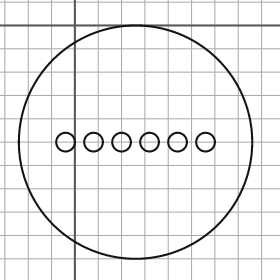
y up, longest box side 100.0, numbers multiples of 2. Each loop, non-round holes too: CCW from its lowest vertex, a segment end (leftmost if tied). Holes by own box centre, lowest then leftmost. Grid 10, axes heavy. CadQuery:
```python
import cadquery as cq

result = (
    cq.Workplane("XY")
    .moveTo(26.0, -50.0)
    .circle(50.0)
    .moveTo(-4.0, -50.0)
    .circle(4.0)
    .moveTo(8.0, -50.0)
    .circle(4.0)
    .moveTo(20.0, -50.0)
    .circle(4.0)
    .moveTo(32.0, -50.0)
    .circle(4.0)
    .moveTo(44.0, -50.0)
    .circle(4.0)
    .moveTo(56.0, -50.0)
    .circle(4.0)
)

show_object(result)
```